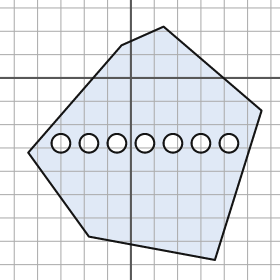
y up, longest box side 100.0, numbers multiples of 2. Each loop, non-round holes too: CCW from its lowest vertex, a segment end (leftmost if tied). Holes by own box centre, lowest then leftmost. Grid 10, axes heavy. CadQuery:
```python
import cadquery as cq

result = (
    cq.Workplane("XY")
    .moveTo(36.0, -78.0)
    .lineTo(56.0, -14.0)
    .lineTo(14.0, 22.0)
    .lineTo(-4.0, 14.0)
    .lineTo(-44.0, -32.0)
    .lineTo(-18.0, -68.0)
    .close()
    .moveTo(-30.0, -28.0)
    .circle(4.0)
    .moveTo(-18.0, -28.0)
    .circle(4.0)
    .moveTo(-6.0, -28.0)
    .circle(4.0)
    .moveTo(6.0, -28.0)
    .circle(4.0)
    .moveTo(18.0, -28.0)
    .circle(4.0)
    .moveTo(30.0, -28.0)
    .circle(4.0)
    .moveTo(42.0, -28.0)
    .circle(4.0)
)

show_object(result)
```